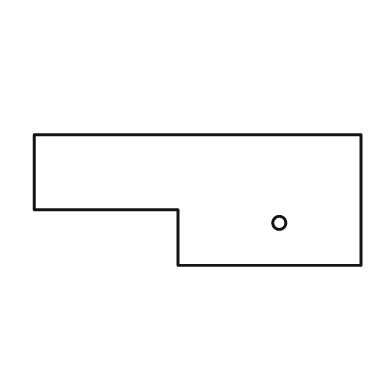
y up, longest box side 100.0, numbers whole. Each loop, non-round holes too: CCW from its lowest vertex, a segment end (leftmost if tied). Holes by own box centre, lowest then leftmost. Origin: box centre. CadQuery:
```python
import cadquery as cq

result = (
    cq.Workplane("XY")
    .moveTo(-6.0, -20.0)
    .lineTo(50.0, -20.0)
    .lineTo(50.0, 20.0)
    .lineTo(-50.0, 20.0)
    .lineTo(-50.0, -3.0)
    .lineTo(-6.0, -3.0)
    .close()
    .moveTo(25.0, -7.0)
    .circle(2.0)
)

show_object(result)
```